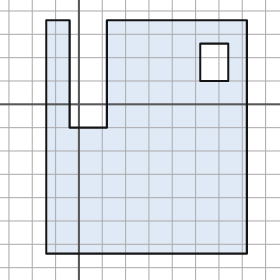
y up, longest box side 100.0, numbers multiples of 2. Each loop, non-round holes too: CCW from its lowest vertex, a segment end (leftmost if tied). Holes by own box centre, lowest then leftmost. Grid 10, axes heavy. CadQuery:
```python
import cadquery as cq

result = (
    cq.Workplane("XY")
    .moveTo(-14.0, -64.0)
    .lineTo(72.0, -64.0)
    .lineTo(72.0, 36.0)
    .lineTo(12.0, 36.0)
    .lineTo(12.0, -10.0)
    .lineTo(-4.0, -10.0)
    .lineTo(-4.0, 36.0)
    .lineTo(-14.0, 36.0)
    .close()
    .moveTo(52.0, 10.0)
    .lineTo(64.0, 10.0)
    .lineTo(64.0, 26.0)
    .lineTo(52.0, 26.0)
    .close()
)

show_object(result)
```